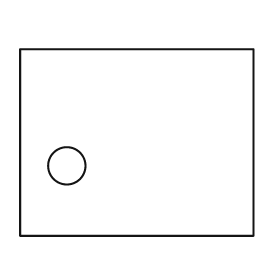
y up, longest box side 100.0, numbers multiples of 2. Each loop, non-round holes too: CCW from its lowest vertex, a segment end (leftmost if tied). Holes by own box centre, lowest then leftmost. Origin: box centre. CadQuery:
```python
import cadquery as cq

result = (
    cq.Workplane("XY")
    .moveTo(-50.0, -40.0)
    .lineTo(50.0, -40.0)
    .lineTo(50.0, 40.0)
    .lineTo(-50.0, 40.0)
    .close()
    .moveTo(-30.0, -10.0)
    .circle(8.0)
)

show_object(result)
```